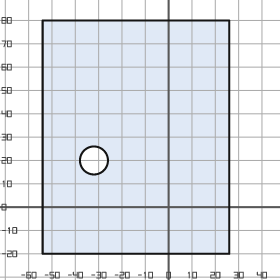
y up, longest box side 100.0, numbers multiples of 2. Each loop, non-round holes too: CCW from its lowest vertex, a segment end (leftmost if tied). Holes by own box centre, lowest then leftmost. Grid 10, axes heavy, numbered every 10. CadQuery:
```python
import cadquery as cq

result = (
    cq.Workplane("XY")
    .moveTo(-54.0, -20.0)
    .lineTo(26.0, -20.0)
    .lineTo(26.0, 80.0)
    .lineTo(-54.0, 80.0)
    .close()
    .moveTo(-32.0, 20.0)
    .circle(6.0)
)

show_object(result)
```